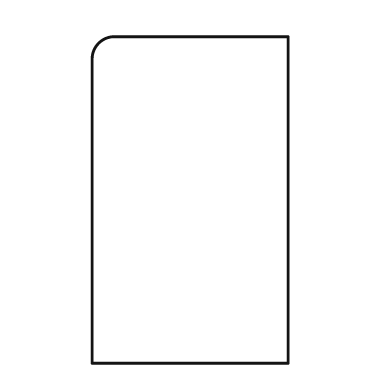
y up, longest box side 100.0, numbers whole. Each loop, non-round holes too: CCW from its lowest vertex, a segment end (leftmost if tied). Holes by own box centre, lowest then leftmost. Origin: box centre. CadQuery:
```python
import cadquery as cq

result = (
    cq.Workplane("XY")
    .moveTo(-30.0, -50.0)
    .lineTo(30.0, -50.0)
    .lineTo(30.0, 50.0)
    .lineTo(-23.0, 50.0)
    .threePointArc((-28.0, 48.0), (-30.0, 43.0))
    .close()
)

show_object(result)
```